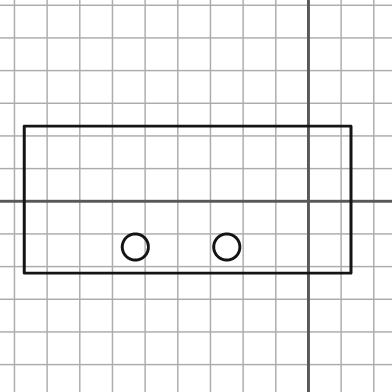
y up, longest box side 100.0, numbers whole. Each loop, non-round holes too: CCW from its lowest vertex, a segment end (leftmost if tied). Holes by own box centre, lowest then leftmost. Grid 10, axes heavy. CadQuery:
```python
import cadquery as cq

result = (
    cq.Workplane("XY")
    .moveTo(-87.0, -22.0)
    .lineTo(13.0, -22.0)
    .lineTo(13.0, 23.0)
    .lineTo(-87.0, 23.0)
    .close()
    .moveTo(-53.0, -14.0)
    .circle(4.0)
    .moveTo(-25.0, -14.0)
    .circle(4.0)
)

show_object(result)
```